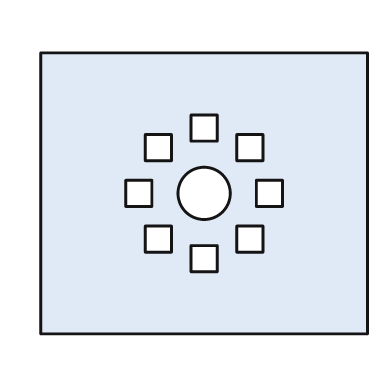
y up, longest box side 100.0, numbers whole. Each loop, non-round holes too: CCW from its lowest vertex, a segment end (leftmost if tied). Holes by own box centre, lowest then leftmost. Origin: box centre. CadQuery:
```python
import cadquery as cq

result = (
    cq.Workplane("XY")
    .moveTo(-50.0, -43.0)
    .lineTo(50.0, -43.0)
    .lineTo(50.0, 43.0)
    .lineTo(-50.0, 43.0)
    .close()
    .moveTo(-4.0, -24.0)
    .lineTo(4.0, -24.0)
    .lineTo(4.0, -16.0)
    .lineTo(-4.0, -16.0)
    .close()
    .moveTo(-18.0, -18.0)
    .lineTo(-10.0, -18.0)
    .lineTo(-10.0, -10.0)
    .lineTo(-18.0, -10.0)
    .close()
    .moveTo(10.0, -18.0)
    .lineTo(18.0, -18.0)
    .lineTo(18.0, -10.0)
    .lineTo(10.0, -10.0)
    .close()
    .moveTo(-24.0, -4.0)
    .lineTo(-16.0, -4.0)
    .lineTo(-16.0, 4.0)
    .lineTo(-24.0, 4.0)
    .close()
    .moveTo(0.0, 0.0)
    .circle(8.0)
    .moveTo(16.0, -4.0)
    .lineTo(24.0, -4.0)
    .lineTo(24.0, 4.0)
    .lineTo(16.0, 4.0)
    .close()
    .moveTo(-18.0, 10.0)
    .lineTo(-10.0, 10.0)
    .lineTo(-10.0, 18.0)
    .lineTo(-18.0, 18.0)
    .close()
    .moveTo(10.0, 10.0)
    .lineTo(18.0, 10.0)
    .lineTo(18.0, 18.0)
    .lineTo(10.0, 18.0)
    .close()
    .moveTo(-4.0, 16.0)
    .lineTo(4.0, 16.0)
    .lineTo(4.0, 24.0)
    .lineTo(-4.0, 24.0)
    .close()
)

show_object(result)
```